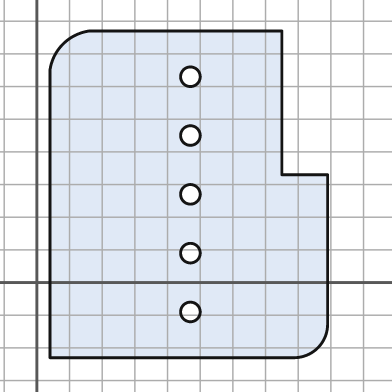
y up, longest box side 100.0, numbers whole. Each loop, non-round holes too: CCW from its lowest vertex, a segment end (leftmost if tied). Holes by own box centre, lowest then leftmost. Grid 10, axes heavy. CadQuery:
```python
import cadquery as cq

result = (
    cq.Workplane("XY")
    .moveTo(4.0, -23.0)
    .lineTo(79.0, -23.0)
    .threePointArc((86.0, -20.0), (89.0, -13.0))
    .lineTo(89.0, 33.0)
    .lineTo(75.0, 33.0)
    .lineTo(75.0, 77.0)
    .lineTo(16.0, 77.0)
    .threePointArc((8.0, 73.0), (4.0, 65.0))
    .close()
    .moveTo(47.0, -9.0)
    .circle(3.0)
    .moveTo(47.0, 9.0)
    .circle(3.0)
    .moveTo(47.0, 27.0)
    .circle(3.0)
    .moveTo(47.0, 45.0)
    .circle(3.0)
    .moveTo(47.0, 63.0)
    .circle(3.0)
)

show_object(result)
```